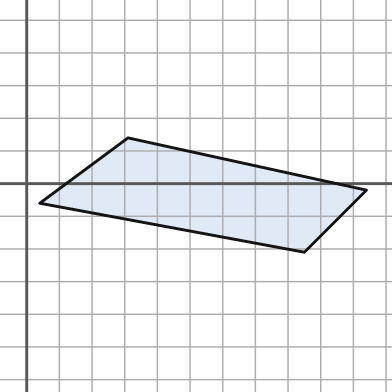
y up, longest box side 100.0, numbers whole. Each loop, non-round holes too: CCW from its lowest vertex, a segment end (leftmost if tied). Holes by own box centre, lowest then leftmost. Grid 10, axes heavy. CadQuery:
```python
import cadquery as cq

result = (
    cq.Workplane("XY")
    .moveTo(85.0, -21.0)
    .lineTo(104.0, -2.0)
    .lineTo(31.0, 14.0)
    .lineTo(4.0, -6.0)
    .close()
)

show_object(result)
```